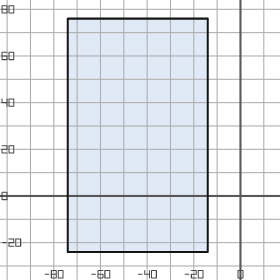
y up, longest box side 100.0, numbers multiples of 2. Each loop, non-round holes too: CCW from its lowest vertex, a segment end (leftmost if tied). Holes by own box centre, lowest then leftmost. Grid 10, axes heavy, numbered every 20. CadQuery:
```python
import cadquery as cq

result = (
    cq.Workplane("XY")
    .moveTo(-74.0, -24.0)
    .lineTo(-14.0, -24.0)
    .lineTo(-14.0, 76.0)
    .lineTo(-74.0, 76.0)
    .close()
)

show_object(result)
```